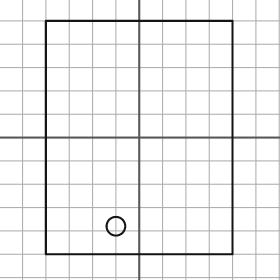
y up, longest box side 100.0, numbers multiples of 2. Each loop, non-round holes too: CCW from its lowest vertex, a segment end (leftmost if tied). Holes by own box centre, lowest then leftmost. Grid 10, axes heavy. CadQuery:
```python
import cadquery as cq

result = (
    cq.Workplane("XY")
    .moveTo(-40.0, -50.0)
    .lineTo(40.0, -50.0)
    .lineTo(40.0, 50.0)
    .lineTo(-40.0, 50.0)
    .close()
    .moveTo(-10.0, -38.0)
    .circle(4.0)
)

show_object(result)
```